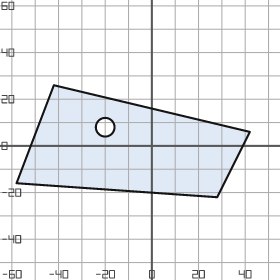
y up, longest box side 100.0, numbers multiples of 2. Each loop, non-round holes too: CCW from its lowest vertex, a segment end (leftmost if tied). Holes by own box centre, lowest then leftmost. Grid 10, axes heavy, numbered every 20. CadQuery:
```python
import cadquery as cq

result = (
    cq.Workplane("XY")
    .moveTo(28.0, -22.0)
    .lineTo(42.0, 6.0)
    .lineTo(-42.0, 26.0)
    .lineTo(-58.0, -16.0)
    .close()
    .moveTo(-20.0, 8.0)
    .circle(4.0)
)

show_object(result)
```